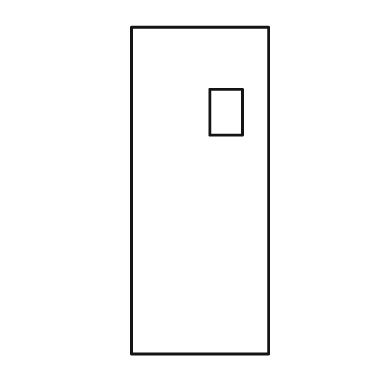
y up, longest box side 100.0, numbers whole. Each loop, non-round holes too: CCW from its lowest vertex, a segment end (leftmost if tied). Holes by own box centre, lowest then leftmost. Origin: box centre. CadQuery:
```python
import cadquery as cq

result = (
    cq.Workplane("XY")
    .moveTo(-21.0, -50.0)
    .lineTo(21.0, -50.0)
    .lineTo(21.0, 50.0)
    .lineTo(-21.0, 50.0)
    .close()
    .moveTo(3.0, 17.0)
    .lineTo(13.0, 17.0)
    .lineTo(13.0, 31.0)
    .lineTo(3.0, 31.0)
    .close()
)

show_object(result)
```